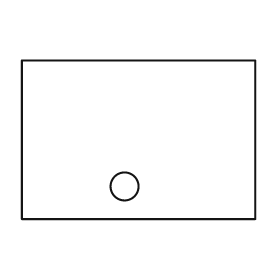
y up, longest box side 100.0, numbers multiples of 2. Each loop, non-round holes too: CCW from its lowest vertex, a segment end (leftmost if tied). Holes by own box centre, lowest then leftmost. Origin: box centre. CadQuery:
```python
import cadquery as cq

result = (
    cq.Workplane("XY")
    .moveTo(-50.0, -34.0)
    .lineTo(50.0, -34.0)
    .lineTo(50.0, 34.0)
    .lineTo(-50.0, 34.0)
    .close()
    .moveTo(-6.0, -20.0)
    .circle(6.0)
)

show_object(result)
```